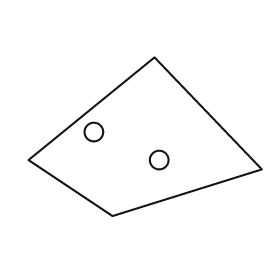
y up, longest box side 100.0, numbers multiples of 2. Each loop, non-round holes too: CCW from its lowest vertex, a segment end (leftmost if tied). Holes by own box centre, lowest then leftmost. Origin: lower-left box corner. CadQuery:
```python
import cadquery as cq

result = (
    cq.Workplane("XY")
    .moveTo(36.0, 0.0)
    .lineTo(100.0, 20.0)
    .lineTo(54.0, 68.0)
    .lineTo(0.0, 24.0)
    .close()
    .moveTo(56.0, 24.0)
    .circle(4.0)
    .moveTo(28.0, 36.0)
    .circle(4.0)
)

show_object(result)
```